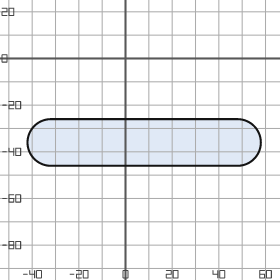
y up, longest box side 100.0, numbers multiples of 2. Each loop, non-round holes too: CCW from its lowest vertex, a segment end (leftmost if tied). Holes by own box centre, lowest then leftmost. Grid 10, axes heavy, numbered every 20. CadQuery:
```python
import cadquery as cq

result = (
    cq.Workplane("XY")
    .moveTo(-32.0, -46.0)
    .lineTo(48.0, -46.0)
    .threePointArc((58.0, -36.0), (48.0, -26.0))
    .lineTo(-32.0, -26.0)
    .threePointArc((-42.0, -36.0), (-32.0, -46.0))
    .close()
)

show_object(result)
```